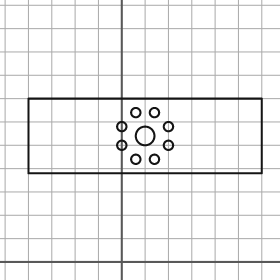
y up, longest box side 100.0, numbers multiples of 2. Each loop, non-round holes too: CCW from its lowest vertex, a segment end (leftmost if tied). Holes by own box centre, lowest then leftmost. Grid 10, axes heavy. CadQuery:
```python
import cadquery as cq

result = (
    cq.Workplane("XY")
    .moveTo(-40.0, 38.0)
    .lineTo(60.0, 38.0)
    .lineTo(60.0, 70.0)
    .lineTo(-40.0, 70.0)
    .close()
    .moveTo(6.0, 44.0)
    .circle(2.0)
    .moveTo(14.0, 44.0)
    .circle(2.0)
    .moveTo(0.0, 50.0)
    .circle(2.0)
    .moveTo(20.0, 50.0)
    .circle(2.0)
    .moveTo(10.0, 54.0)
    .circle(4.0)
    .moveTo(0.0, 58.0)
    .circle(2.0)
    .moveTo(20.0, 58.0)
    .circle(2.0)
    .moveTo(6.0, 64.0)
    .circle(2.0)
    .moveTo(14.0, 64.0)
    .circle(2.0)
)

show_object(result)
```